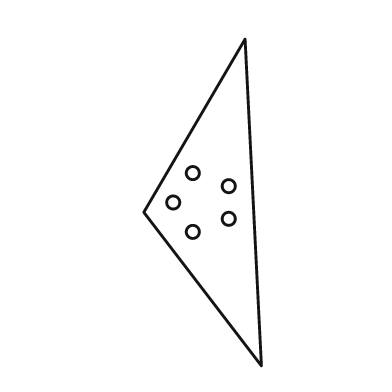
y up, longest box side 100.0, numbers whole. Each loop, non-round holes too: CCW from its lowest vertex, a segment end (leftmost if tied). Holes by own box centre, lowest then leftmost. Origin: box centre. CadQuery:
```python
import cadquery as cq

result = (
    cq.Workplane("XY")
    .moveTo(18.0, -50.0)
    .lineTo(13.0, 50.0)
    .lineTo(-18.0, -3.0)
    .close()
    .moveTo(-3.0, -9.0)
    .circle(2.0)
    .moveTo(8.0, -5.0)
    .circle(2.0)
    .moveTo(-9.0, 0.0)
    .circle(2.0)
    .moveTo(8.0, 5.0)
    .circle(2.0)
    .moveTo(-3.0, 9.0)
    .circle(2.0)
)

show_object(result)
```